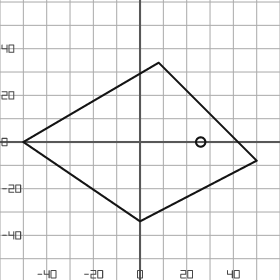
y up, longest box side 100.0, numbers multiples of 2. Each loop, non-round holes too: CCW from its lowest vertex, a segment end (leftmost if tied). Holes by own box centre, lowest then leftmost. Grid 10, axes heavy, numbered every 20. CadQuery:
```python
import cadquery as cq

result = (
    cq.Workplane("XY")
    .moveTo(0.0, -34.0)
    .lineTo(50.0, -8.0)
    .lineTo(8.0, 34.0)
    .lineTo(-50.0, 0.0)
    .close()
    .moveTo(26.0, 0.0)
    .circle(2.0)
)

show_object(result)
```